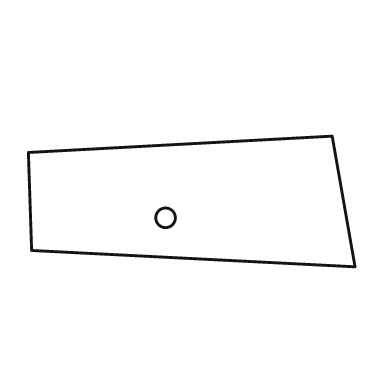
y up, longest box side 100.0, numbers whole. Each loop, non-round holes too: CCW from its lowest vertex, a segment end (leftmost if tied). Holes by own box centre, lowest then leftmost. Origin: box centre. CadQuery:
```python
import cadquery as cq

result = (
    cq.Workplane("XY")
    .moveTo(50.0, -20.0)
    .lineTo(43.0, 20.0)
    .lineTo(-50.0, 15.0)
    .lineTo(-49.0, -15.0)
    .close()
    .moveTo(-8.0, -5.0)
    .circle(3.0)
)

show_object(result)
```